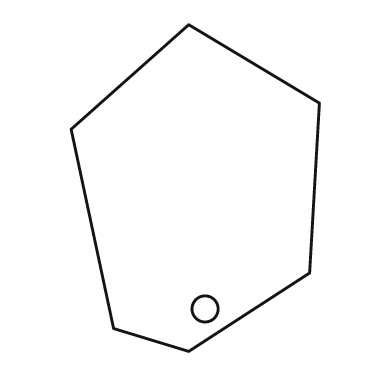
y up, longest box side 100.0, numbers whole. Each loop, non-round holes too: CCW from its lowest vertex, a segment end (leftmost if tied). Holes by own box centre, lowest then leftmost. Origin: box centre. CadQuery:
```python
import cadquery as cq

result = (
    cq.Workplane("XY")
    .moveTo(-2.0, -50.0)
    .lineTo(35.0, -26.0)
    .lineTo(38.0, 26.0)
    .lineTo(-2.0, 50.0)
    .lineTo(-38.0, 18.0)
    .lineTo(-25.0, -43.0)
    .close()
    .moveTo(3.0, -37.0)
    .circle(4.0)
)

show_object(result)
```